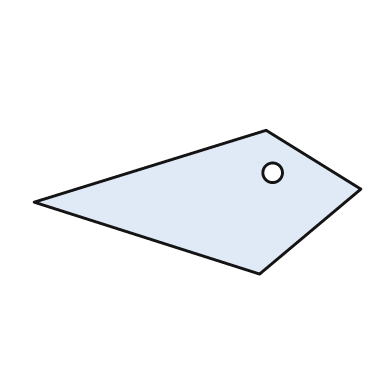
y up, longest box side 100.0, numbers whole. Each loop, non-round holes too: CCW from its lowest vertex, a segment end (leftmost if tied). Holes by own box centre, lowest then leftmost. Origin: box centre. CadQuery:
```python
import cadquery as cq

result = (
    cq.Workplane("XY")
    .moveTo(19.0, -22.0)
    .lineTo(50.0, 4.0)
    .lineTo(21.0, 22.0)
    .lineTo(-50.0, 0.0)
    .close()
    .moveTo(23.0, 9.0)
    .circle(3.0)
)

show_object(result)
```